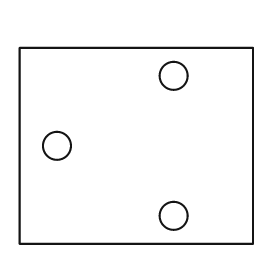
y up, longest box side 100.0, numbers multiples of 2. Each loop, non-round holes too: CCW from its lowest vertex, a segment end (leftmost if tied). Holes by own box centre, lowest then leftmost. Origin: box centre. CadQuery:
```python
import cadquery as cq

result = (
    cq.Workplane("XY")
    .moveTo(-50.0, -42.0)
    .lineTo(50.0, -42.0)
    .lineTo(50.0, 42.0)
    .lineTo(-50.0, 42.0)
    .close()
    .moveTo(16.0, -30.0)
    .circle(6.0)
    .moveTo(-34.0, 0.0)
    .circle(6.0)
    .moveTo(16.0, 30.0)
    .circle(6.0)
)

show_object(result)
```